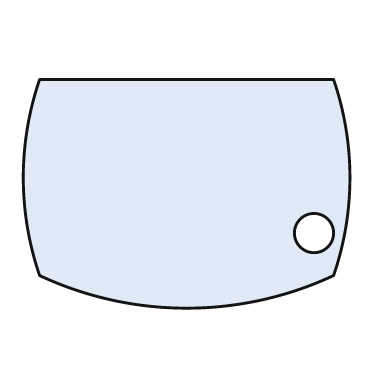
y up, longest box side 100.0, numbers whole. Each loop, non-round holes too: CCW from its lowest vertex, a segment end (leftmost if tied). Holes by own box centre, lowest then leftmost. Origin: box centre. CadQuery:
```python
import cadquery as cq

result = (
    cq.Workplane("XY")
    .moveTo(-45.0, -25.0)
    .threePointArc((0.0, -35.0), (45.0, -25.0))
    .threePointArc((50.0, 5.0), (45.0, 35.0))
    .lineTo(-45.0, 35.0)
    .threePointArc((-50.0, 5.0), (-45.0, -25.0))
    .close()
    .moveTo(39.0, -12.0)
    .circle(6.0)
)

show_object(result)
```